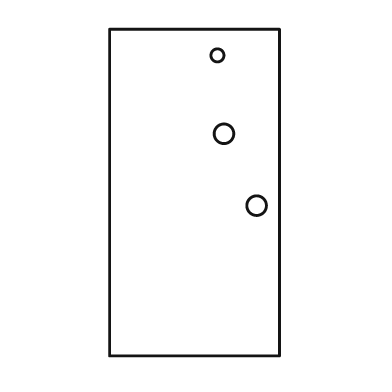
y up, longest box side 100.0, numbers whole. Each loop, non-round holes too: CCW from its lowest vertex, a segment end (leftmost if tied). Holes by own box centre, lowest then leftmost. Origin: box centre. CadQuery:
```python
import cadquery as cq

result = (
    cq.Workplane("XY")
    .moveTo(-26.0, -50.0)
    .lineTo(26.0, -50.0)
    .lineTo(26.0, 50.0)
    .lineTo(-26.0, 50.0)
    .close()
    .moveTo(19.0, -4.0)
    .circle(3.0)
    .moveTo(9.0, 18.0)
    .circle(3.0)
    .moveTo(7.0, 42.0)
    .circle(2.0)
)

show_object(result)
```